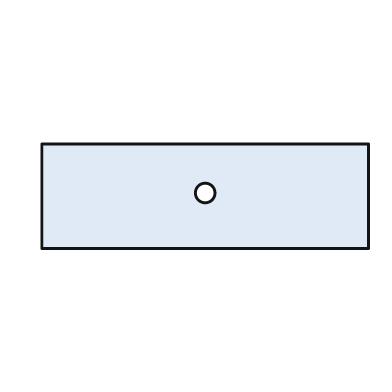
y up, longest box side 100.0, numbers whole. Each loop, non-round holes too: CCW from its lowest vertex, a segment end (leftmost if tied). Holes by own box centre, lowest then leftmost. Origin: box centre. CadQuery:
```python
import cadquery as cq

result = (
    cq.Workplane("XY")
    .moveTo(-50.0, -16.0)
    .lineTo(50.0, -16.0)
    .lineTo(50.0, 16.0)
    .lineTo(-50.0, 16.0)
    .close()
    .moveTo(0.0, 1.0)
    .circle(3.0)
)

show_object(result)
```